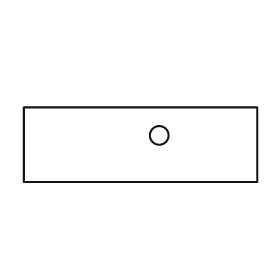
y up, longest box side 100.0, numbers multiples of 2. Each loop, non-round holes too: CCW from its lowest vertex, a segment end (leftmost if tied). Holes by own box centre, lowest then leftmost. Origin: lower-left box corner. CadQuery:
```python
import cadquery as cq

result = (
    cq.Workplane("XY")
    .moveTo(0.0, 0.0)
    .lineTo(100.0, 0.0)
    .lineTo(100.0, 32.0)
    .lineTo(0.0, 32.0)
    .close()
    .moveTo(58.0, 20.0)
    .circle(4.0)
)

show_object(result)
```